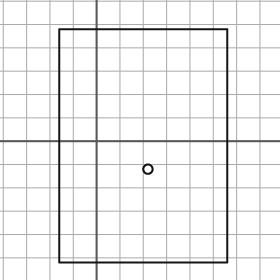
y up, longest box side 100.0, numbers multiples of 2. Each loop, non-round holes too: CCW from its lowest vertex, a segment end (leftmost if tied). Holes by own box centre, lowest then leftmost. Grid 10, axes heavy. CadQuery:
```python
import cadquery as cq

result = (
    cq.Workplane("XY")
    .moveTo(-16.0, -52.0)
    .lineTo(56.0, -52.0)
    .lineTo(56.0, 48.0)
    .lineTo(-16.0, 48.0)
    .close()
    .moveTo(22.0, -12.0)
    .circle(2.0)
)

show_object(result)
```